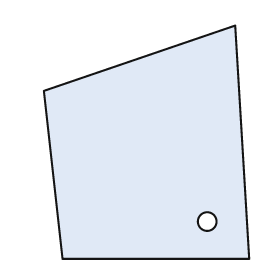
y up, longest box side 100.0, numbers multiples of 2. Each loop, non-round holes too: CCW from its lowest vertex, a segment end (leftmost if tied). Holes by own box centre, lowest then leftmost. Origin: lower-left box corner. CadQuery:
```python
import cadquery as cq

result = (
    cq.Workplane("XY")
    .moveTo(8.0, 0.0)
    .lineTo(88.0, 0.0)
    .lineTo(82.0, 100.0)
    .lineTo(0.0, 72.0)
    .close()
    .moveTo(70.0, 16.0)
    .circle(4.0)
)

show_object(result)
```